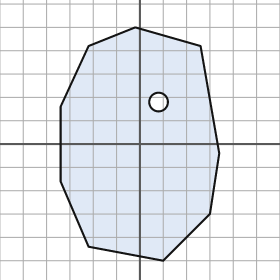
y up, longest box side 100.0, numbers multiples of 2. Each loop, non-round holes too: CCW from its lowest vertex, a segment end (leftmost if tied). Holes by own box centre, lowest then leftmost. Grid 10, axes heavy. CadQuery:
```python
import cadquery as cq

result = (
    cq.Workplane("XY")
    .moveTo(10.0, -50.0)
    .lineTo(30.0, -30.0)
    .lineTo(34.0, -4.0)
    .lineTo(26.0, 42.0)
    .lineTo(-2.0, 50.0)
    .lineTo(-22.0, 42.0)
    .lineTo(-34.0, 16.0)
    .lineTo(-34.0, -16.0)
    .lineTo(-22.0, -44.0)
    .close()
    .moveTo(8.0, 18.0)
    .circle(4.0)
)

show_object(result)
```